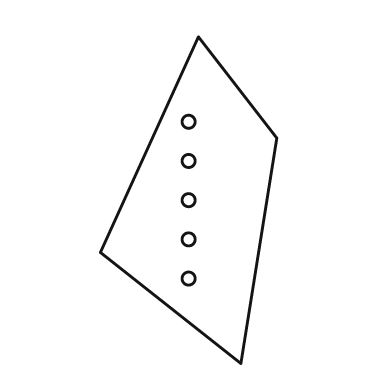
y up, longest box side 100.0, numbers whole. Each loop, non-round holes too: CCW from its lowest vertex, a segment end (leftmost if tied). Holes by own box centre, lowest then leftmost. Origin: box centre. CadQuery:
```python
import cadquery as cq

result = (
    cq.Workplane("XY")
    .moveTo(16.0, -50.0)
    .lineTo(27.0, 19.0)
    .lineTo(3.0, 50.0)
    .lineTo(-27.0, -16.0)
    .close()
    .moveTo(0.0, -24.0)
    .circle(2.0)
    .moveTo(0.0, -12.0)
    .circle(2.0)
    .moveTo(0.0, 0.0)
    .circle(2.0)
    .moveTo(0.0, 12.0)
    .circle(2.0)
    .moveTo(0.0, 24.0)
    .circle(2.0)
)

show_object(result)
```